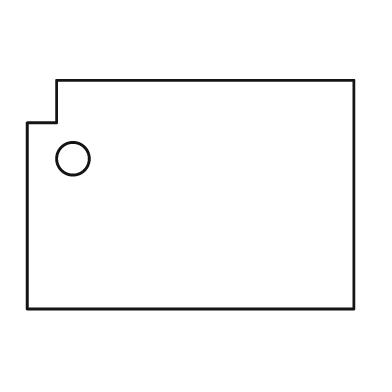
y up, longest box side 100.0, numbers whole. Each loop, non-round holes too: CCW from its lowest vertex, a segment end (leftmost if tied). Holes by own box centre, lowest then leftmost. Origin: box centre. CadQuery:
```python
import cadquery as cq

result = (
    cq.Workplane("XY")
    .moveTo(-50.0, -35.0)
    .lineTo(50.0, -35.0)
    .lineTo(50.0, 35.0)
    .lineTo(-41.0, 35.0)
    .lineTo(-41.0, 22.0)
    .lineTo(-50.0, 22.0)
    .close()
    .moveTo(-36.0, 11.0)
    .circle(5.0)
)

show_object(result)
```